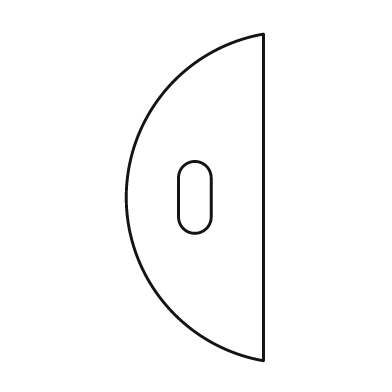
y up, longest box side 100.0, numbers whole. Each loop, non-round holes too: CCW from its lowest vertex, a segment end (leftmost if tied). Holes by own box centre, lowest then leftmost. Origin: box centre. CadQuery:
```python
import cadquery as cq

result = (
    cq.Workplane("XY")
    .moveTo(21.0, -50.0)
    .lineTo(21.0, 50.0)
    .threePointArc((-21.0, 0.0), (21.0, -50.0))
    .close()
    .moveTo(-5.0, -6.0)
    .threePointArc((0.0, -11.0), (5.0, -6.0))
    .lineTo(5.0, 6.0)
    .threePointArc((0.0, 11.0), (-5.0, 6.0))
    .close()
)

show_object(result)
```